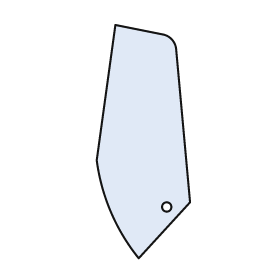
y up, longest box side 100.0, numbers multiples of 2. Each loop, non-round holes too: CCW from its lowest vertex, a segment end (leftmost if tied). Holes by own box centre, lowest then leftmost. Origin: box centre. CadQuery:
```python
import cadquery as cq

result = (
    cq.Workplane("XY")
    .moveTo(-2.0, -50.0)
    .lineTo(20.0, -26.0)
    .lineTo(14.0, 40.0)
    .threePointArc((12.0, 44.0), (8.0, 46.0))
    .lineTo(-12.0, 50.0)
    .lineTo(-20.0, -8.0)
    .threePointArc((-14.0, -30.0), (-2.0, -50.0))
    .close()
    .moveTo(10.0, -28.0)
    .circle(2.0)
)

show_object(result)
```